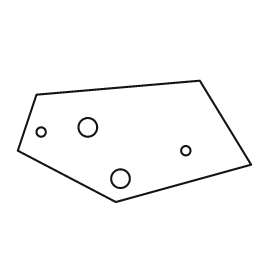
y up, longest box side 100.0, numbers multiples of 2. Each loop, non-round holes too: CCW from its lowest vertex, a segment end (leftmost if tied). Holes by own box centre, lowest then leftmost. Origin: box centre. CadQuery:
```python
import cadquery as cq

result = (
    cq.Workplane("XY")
    .moveTo(-8.0, -26.0)
    .lineTo(50.0, -10.0)
    .lineTo(28.0, 26.0)
    .lineTo(-42.0, 20.0)
    .lineTo(-50.0, -4.0)
    .close()
    .moveTo(-6.0, -16.0)
    .circle(4.0)
    .moveTo(22.0, -4.0)
    .circle(2.0)
    .moveTo(-40.0, 4.0)
    .circle(2.0)
    .moveTo(-20.0, 6.0)
    .circle(4.0)
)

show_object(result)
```